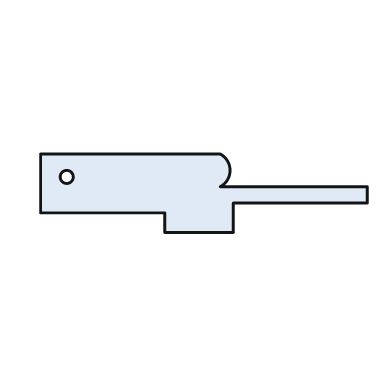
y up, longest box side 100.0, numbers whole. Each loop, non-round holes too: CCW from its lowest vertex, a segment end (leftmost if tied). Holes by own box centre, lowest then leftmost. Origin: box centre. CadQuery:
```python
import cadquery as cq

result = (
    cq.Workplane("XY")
    .moveTo(-12.0, -12.0)
    .lineTo(9.0, -12.0)
    .lineTo(9.0, -3.0)
    .lineTo(50.0, -3.0)
    .lineTo(50.0, 2.0)
    .lineTo(5.0, 2.0)
    .threePointArc((8.0, 7.0), (5.0, 12.0))
    .lineTo(-50.0, 12.0)
    .lineTo(-50.0, -6.0)
    .lineTo(-12.0, -6.0)
    .close()
    .moveTo(-42.0, 5.0)
    .circle(2.0)
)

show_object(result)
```